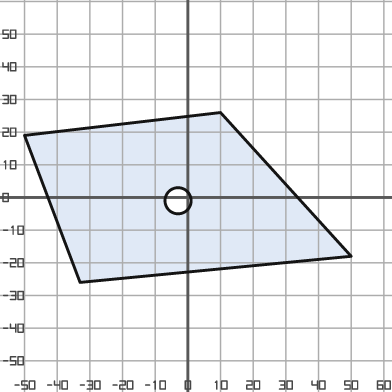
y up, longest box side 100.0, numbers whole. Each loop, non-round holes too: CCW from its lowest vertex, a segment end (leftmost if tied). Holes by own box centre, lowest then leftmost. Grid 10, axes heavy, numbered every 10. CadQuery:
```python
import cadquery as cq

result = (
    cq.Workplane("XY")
    .moveTo(-33.0, -26.0)
    .lineTo(50.0, -18.0)
    .lineTo(10.0, 26.0)
    .lineTo(-50.0, 19.0)
    .close()
    .moveTo(-3.0, -1.0)
    .circle(4.0)
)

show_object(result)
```